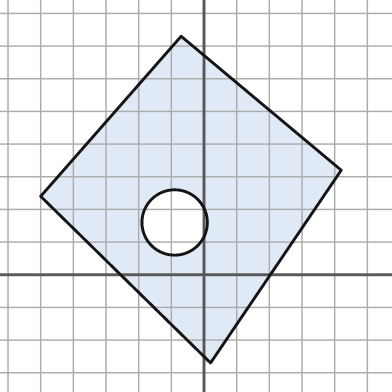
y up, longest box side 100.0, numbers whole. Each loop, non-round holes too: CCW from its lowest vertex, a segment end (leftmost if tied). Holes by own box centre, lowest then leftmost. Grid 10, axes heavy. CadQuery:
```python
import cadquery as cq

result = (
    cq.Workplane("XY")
    .moveTo(2.0, -27.0)
    .lineTo(42.0, 32.0)
    .lineTo(-7.0, 73.0)
    .lineTo(-50.0, 24.0)
    .close()
    .moveTo(-9.0, 16.0)
    .circle(10.0)
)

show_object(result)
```